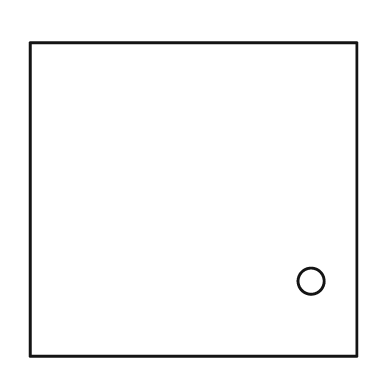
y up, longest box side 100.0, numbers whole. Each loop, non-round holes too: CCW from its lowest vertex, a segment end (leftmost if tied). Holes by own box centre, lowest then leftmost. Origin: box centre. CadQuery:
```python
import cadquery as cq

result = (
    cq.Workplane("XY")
    .moveTo(-50.0, -48.0)
    .lineTo(50.0, -48.0)
    .lineTo(50.0, 48.0)
    .lineTo(-50.0, 48.0)
    .close()
    .moveTo(36.0, -25.0)
    .circle(4.0)
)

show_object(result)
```